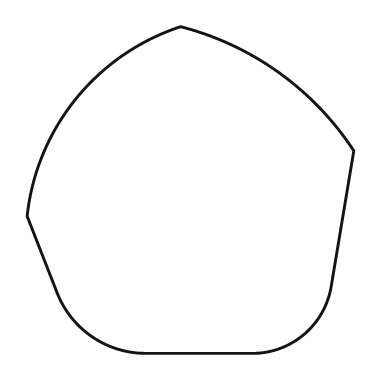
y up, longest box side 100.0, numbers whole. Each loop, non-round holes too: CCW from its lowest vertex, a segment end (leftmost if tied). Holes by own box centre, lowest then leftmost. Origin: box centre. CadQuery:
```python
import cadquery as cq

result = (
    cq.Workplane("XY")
    .moveTo(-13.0, -50.0)
    .lineTo(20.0, -50.0)
    .threePointArc((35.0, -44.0), (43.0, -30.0))
    .lineTo(50.0, 12.0)
    .threePointArc((27.0, 36.0), (-3.0, 50.0))
    .threePointArc((-35.0, 28.0), (-50.0, -8.0))
    .lineTo(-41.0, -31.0)
    .threePointArc((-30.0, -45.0), (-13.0, -50.0))
    .close()
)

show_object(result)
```